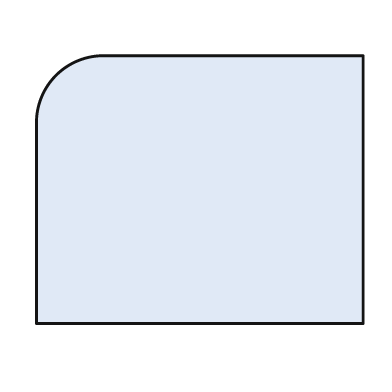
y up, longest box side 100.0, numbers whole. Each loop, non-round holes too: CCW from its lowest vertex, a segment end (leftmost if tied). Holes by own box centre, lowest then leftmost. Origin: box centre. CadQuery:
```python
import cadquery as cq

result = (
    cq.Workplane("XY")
    .moveTo(-50.0, -41.0)
    .lineTo(50.0, -41.0)
    .lineTo(50.0, 41.0)
    .lineTo(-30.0, 41.0)
    .threePointArc((-44.0, 35.0), (-50.0, 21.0))
    .close()
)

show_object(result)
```